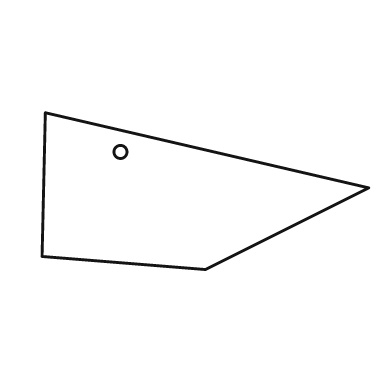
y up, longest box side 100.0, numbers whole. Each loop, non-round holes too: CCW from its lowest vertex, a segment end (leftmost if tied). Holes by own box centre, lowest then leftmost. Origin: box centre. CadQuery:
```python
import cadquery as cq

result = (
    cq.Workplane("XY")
    .moveTo(0.0, -24.0)
    .lineTo(50.0, 1.0)
    .lineTo(-49.0, 24.0)
    .lineTo(-50.0, -20.0)
    .close()
    .moveTo(-26.0, 12.0)
    .circle(2.0)
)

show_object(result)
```